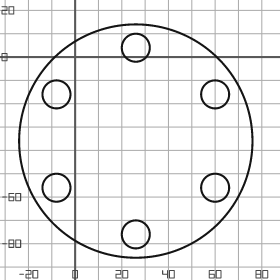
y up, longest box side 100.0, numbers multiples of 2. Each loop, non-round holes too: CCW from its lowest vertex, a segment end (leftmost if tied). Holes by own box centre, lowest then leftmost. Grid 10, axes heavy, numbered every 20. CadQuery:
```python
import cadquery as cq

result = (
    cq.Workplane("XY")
    .moveTo(26.0, -36.0)
    .circle(50.0)
    .moveTo(26.0, -76.0)
    .circle(6.0)
    .moveTo(-8.0, -56.0)
    .circle(6.0)
    .moveTo(60.0, -56.0)
    .circle(6.0)
    .moveTo(-8.0, -16.0)
    .circle(6.0)
    .moveTo(60.0, -16.0)
    .circle(6.0)
    .moveTo(26.0, 4.0)
    .circle(6.0)
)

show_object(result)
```